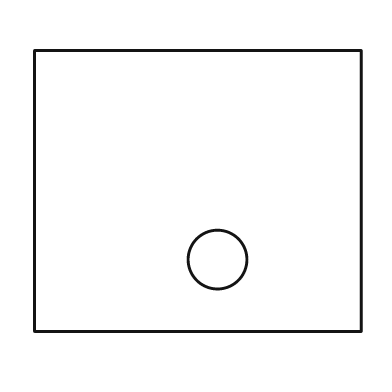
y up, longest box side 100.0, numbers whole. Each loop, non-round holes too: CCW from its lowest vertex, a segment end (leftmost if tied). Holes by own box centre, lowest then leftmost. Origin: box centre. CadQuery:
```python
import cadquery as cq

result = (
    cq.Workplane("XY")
    .moveTo(-50.0, -43.0)
    .lineTo(50.0, -43.0)
    .lineTo(50.0, 43.0)
    .lineTo(-50.0, 43.0)
    .close()
    .moveTo(6.0, -21.0)
    .circle(9.0)
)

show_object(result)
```